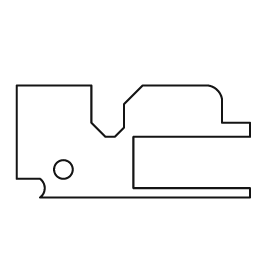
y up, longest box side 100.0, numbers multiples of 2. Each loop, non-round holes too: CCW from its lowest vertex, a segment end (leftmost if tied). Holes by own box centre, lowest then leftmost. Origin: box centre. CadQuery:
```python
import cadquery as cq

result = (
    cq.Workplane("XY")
    .moveTo(-40.0, -24.0)
    .lineTo(50.0, -24.0)
    .lineTo(50.0, -20.0)
    .lineTo(0.0, -20.0)
    .lineTo(0.0, 2.0)
    .lineTo(50.0, 2.0)
    .lineTo(50.0, 8.0)
    .lineTo(38.0, 8.0)
    .lineTo(38.0, 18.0)
    .threePointArc((36.0, 22.0), (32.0, 24.0))
    .lineTo(4.0, 24.0)
    .lineTo(-4.0, 16.0)
    .lineTo(-4.0, 6.0)
    .lineTo(-8.0, 2.0)
    .lineTo(-12.0, 2.0)
    .lineTo(-18.0, 8.0)
    .lineTo(-18.0, 24.0)
    .lineTo(-50.0, 24.0)
    .lineTo(-50.0, -16.0)
    .lineTo(-40.0, -16.0)
    .threePointArc((-38.0, -20.0), (-40.0, -24.0))
    .close()
    .moveTo(-30.0, -12.0)
    .circle(4.0)
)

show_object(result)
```